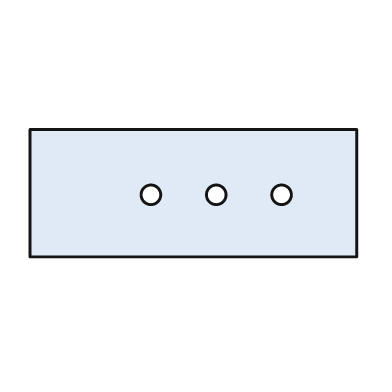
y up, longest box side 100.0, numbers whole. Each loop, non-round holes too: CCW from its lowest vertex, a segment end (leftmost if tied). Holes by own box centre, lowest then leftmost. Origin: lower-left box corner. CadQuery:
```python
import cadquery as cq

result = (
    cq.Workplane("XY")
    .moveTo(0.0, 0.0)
    .lineTo(100.0, 0.0)
    .lineTo(100.0, 39.0)
    .lineTo(0.0, 39.0)
    .close()
    .moveTo(37.0, 19.0)
    .circle(3.0)
    .moveTo(57.0, 19.0)
    .circle(3.0)
    .moveTo(77.0, 19.0)
    .circle(3.0)
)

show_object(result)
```